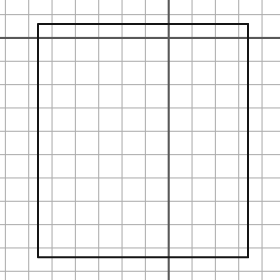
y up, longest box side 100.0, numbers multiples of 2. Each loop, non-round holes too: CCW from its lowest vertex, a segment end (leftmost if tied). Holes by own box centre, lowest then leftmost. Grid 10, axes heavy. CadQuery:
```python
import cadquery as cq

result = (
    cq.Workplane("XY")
    .moveTo(-56.0, -94.0)
    .lineTo(34.0, -94.0)
    .lineTo(34.0, 6.0)
    .lineTo(-56.0, 6.0)
    .close()
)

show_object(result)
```